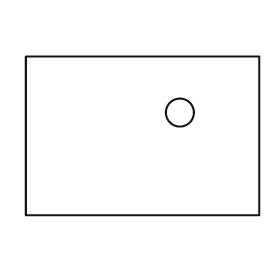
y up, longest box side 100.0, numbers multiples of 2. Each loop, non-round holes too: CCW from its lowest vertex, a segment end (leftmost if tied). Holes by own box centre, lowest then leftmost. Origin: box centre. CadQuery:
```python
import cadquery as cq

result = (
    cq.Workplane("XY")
    .moveTo(-50.0, -34.0)
    .lineTo(50.0, -34.0)
    .lineTo(50.0, 34.0)
    .lineTo(-50.0, 34.0)
    .close()
    .moveTo(16.0, 10.0)
    .circle(6.0)
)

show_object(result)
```